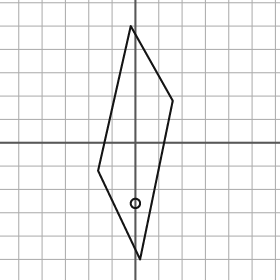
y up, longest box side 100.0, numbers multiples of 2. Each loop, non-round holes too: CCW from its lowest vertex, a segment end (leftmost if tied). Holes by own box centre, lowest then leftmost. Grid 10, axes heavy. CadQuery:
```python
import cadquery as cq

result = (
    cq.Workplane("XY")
    .moveTo(2.0, -50.0)
    .lineTo(16.0, 18.0)
    .lineTo(-2.0, 50.0)
    .lineTo(-16.0, -12.0)
    .close()
    .moveTo(0.0, -26.0)
    .circle(2.0)
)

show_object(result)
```